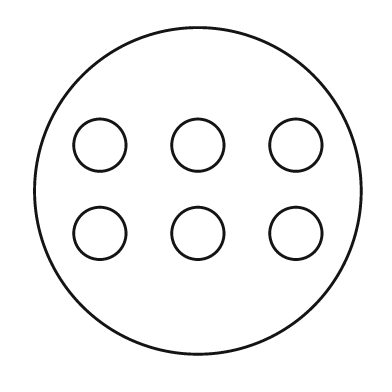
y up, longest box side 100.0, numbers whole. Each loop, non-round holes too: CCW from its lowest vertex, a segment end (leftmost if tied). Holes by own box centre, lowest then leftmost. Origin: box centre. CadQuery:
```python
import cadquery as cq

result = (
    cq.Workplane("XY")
    .moveTo(0.0, 0.0)
    .circle(50.0)
    .moveTo(-30.0, -13.0)
    .circle(8.0)
    .moveTo(0.0, -13.0)
    .circle(8.0)
    .moveTo(30.0, -13.0)
    .circle(8.0)
    .moveTo(-30.0, 14.0)
    .circle(8.0)
    .moveTo(0.0, 14.0)
    .circle(8.0)
    .moveTo(30.0, 14.0)
    .circle(8.0)
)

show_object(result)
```